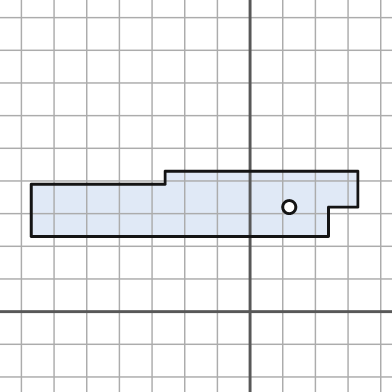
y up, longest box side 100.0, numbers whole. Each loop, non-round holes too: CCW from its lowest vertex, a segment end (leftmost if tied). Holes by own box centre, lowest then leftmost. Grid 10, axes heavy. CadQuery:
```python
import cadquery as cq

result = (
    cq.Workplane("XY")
    .moveTo(-67.0, 23.0)
    .lineTo(24.0, 23.0)
    .lineTo(24.0, 32.0)
    .lineTo(33.0, 32.0)
    .lineTo(33.0, 43.0)
    .lineTo(-26.0, 43.0)
    .lineTo(-26.0, 39.0)
    .lineTo(-67.0, 39.0)
    .close()
    .moveTo(12.0, 32.0)
    .circle(2.0)
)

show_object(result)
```